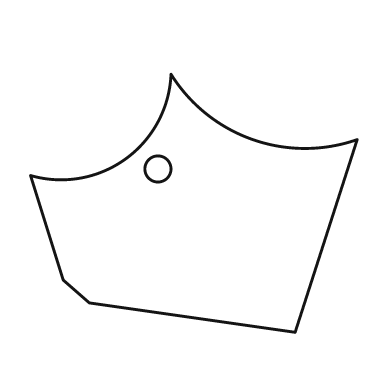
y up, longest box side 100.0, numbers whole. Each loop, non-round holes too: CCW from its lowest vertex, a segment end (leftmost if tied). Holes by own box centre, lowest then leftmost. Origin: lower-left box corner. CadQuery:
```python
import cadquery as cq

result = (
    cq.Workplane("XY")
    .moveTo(81.0, 0.0)
    .lineTo(100.0, 59.0)
    .threePointArc((68.0, 59.0), (43.0, 79.0))
    .threePointArc((29.0, 53.0), (0.0, 48.0))
    .lineTo(10.0, 16.0)
    .lineTo(18.0, 9.0)
    .close()
    .moveTo(39.0, 50.0)
    .circle(4.0)
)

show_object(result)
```